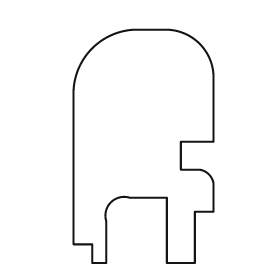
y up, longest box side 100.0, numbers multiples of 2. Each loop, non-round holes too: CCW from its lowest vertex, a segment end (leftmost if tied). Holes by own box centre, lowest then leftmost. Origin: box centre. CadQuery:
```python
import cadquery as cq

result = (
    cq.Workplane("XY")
    .moveTo(-22.0, -50.0)
    .lineTo(-16.0, -50.0)
    .lineTo(-16.0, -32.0)
    .threePointArc((-14.0, -24.0), (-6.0, -22.0))
    .lineTo(10.0, -22.0)
    .lineTo(10.0, -50.0)
    .lineTo(22.0, -50.0)
    .lineTo(22.0, -28.0)
    .lineTo(30.0, -28.0)
    .lineTo(30.0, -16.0)
    .threePointArc((28.0, -12.0), (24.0, -10.0))
    .lineTo(16.0, -10.0)
    .lineTo(16.0, 2.0)
    .lineTo(30.0, 2.0)
    .lineTo(30.0, 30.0)
    .threePointArc((24.0, 44.0), (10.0, 50.0))
    .lineTo(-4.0, 50.0)
    .threePointArc((-22.0, 42.0), (-30.0, 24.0))
    .lineTo(-30.0, -42.0)
    .lineTo(-22.0, -42.0)
    .close()
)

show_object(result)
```